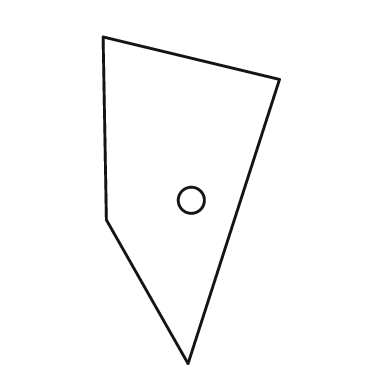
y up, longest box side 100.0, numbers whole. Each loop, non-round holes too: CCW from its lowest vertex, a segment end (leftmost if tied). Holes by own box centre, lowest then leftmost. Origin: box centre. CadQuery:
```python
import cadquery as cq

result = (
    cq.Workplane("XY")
    .moveTo(-1.0, -50.0)
    .lineTo(27.0, 37.0)
    .lineTo(-27.0, 50.0)
    .lineTo(-26.0, -6.0)
    .close()
    .moveTo(0.0, 0.0)
    .circle(4.0)
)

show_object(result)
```